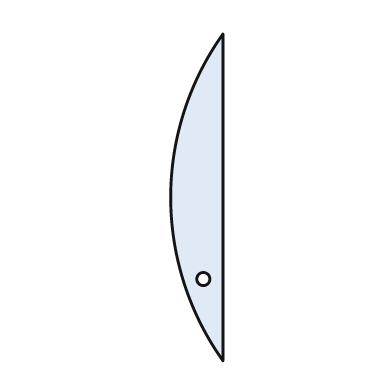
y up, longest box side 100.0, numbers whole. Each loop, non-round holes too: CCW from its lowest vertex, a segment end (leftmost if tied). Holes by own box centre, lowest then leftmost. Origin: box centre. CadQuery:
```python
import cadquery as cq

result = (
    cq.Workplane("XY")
    .moveTo(8.0, -50.0)
    .lineTo(8.0, 50.0)
    .threePointArc((-8.0, 0.0), (8.0, -50.0))
    .close()
    .moveTo(2.0, -25.0)
    .circle(2.0)
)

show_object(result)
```